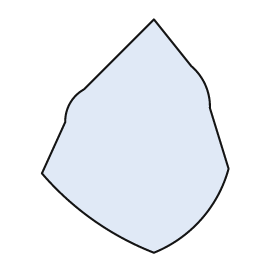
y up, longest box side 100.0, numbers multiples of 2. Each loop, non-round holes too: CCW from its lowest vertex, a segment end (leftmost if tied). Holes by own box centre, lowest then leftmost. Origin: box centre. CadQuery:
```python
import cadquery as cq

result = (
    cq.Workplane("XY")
    .moveTo(8.0, -50.0)
    .threePointArc((28.0, -36.0), (40.0, -14.0))
    .lineTo(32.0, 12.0)
    .threePointArc((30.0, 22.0), (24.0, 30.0))
    .lineTo(8.0, 50.0)
    .lineTo(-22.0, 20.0)
    .threePointArc((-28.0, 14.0), (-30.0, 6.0))
    .lineTo(-40.0, -16.0)
    .threePointArc((-18.0, -36.0), (8.0, -50.0))
    .close()
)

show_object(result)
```